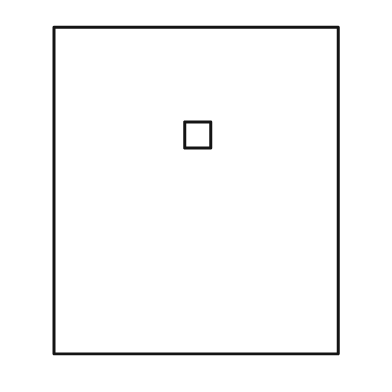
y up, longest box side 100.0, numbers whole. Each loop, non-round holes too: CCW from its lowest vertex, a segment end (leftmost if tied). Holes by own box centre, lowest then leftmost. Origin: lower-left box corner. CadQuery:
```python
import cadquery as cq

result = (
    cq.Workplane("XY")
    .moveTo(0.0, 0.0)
    .lineTo(87.0, 0.0)
    .lineTo(87.0, 100.0)
    .lineTo(0.0, 100.0)
    .close()
    .moveTo(40.0, 63.0)
    .lineTo(48.0, 63.0)
    .lineTo(48.0, 71.0)
    .lineTo(40.0, 71.0)
    .close()
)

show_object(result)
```